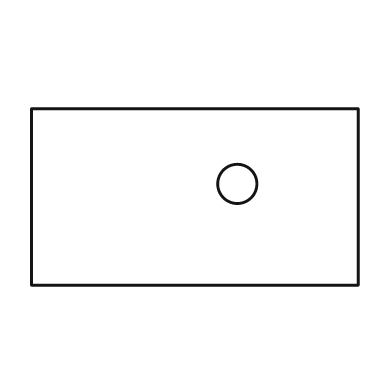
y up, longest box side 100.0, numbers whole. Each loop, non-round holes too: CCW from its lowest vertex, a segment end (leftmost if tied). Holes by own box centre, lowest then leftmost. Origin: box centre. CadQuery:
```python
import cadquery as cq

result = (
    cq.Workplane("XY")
    .moveTo(-50.0, -27.0)
    .lineTo(50.0, -27.0)
    .lineTo(50.0, 27.0)
    .lineTo(-50.0, 27.0)
    .close()
    .moveTo(13.0, 4.0)
    .circle(6.0)
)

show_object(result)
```